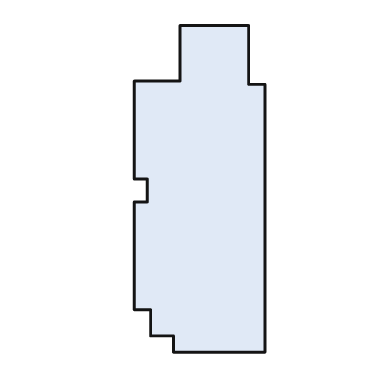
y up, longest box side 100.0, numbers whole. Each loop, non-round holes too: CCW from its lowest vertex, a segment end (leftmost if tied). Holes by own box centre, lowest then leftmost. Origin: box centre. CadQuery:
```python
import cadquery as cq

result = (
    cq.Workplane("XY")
    .moveTo(-8.0, -50.0)
    .lineTo(20.0, -50.0)
    .lineTo(20.0, 32.0)
    .lineTo(15.0, 32.0)
    .lineTo(15.0, 50.0)
    .lineTo(-6.0, 50.0)
    .lineTo(-6.0, 33.0)
    .lineTo(-20.0, 33.0)
    .lineTo(-20.0, 3.0)
    .lineTo(-16.0, 3.0)
    .lineTo(-16.0, -4.0)
    .lineTo(-20.0, -4.0)
    .lineTo(-20.0, -37.0)
    .lineTo(-15.0, -37.0)
    .lineTo(-15.0, -45.0)
    .lineTo(-8.0, -45.0)
    .close()
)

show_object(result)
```